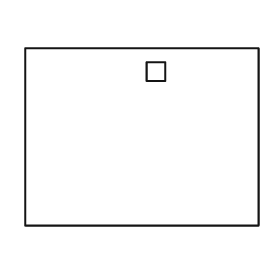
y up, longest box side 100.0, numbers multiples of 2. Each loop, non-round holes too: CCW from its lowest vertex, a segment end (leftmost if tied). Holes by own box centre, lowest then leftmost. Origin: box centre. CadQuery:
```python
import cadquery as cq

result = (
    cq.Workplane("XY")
    .moveTo(-50.0, -38.0)
    .lineTo(50.0, -38.0)
    .lineTo(50.0, 38.0)
    .lineTo(-50.0, 38.0)
    .close()
    .moveTo(2.0, 24.0)
    .lineTo(10.0, 24.0)
    .lineTo(10.0, 32.0)
    .lineTo(2.0, 32.0)
    .close()
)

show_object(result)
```